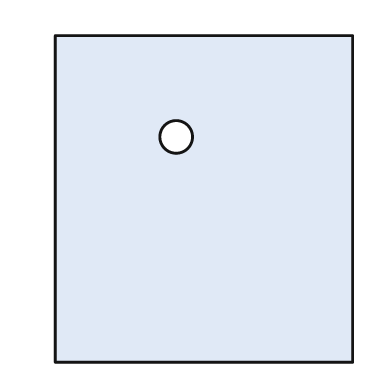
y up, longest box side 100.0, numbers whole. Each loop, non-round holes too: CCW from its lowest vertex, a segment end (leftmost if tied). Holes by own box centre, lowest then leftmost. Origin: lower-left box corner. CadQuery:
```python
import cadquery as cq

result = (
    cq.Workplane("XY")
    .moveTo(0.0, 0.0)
    .lineTo(91.0, 0.0)
    .lineTo(91.0, 100.0)
    .lineTo(0.0, 100.0)
    .close()
    .moveTo(37.0, 69.0)
    .circle(5.0)
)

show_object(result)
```